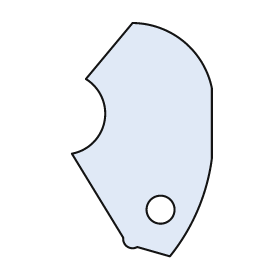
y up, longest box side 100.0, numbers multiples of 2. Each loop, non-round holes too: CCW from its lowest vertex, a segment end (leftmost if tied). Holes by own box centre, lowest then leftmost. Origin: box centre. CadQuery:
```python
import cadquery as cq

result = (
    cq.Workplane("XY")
    .moveTo(12.0, -50.0)
    .threePointArc((24.0, -30.0), (30.0, -8.0))
    .lineTo(30.0, 22.0)
    .threePointArc((18.0, 42.0), (-4.0, 50.0))
    .lineTo(-24.0, 26.0)
    .threePointArc((-16.0, 8.0), (-30.0, -6.0))
    .lineTo(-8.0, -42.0)
    .threePointArc((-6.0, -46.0), (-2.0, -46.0))
    .close()
    .moveTo(8.0, -30.0)
    .circle(6.0)
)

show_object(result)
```